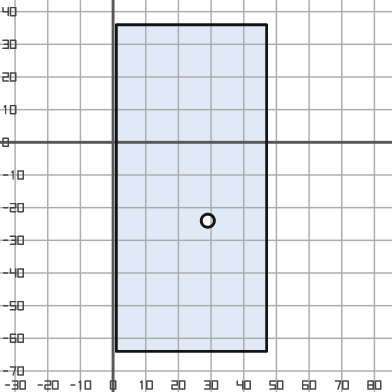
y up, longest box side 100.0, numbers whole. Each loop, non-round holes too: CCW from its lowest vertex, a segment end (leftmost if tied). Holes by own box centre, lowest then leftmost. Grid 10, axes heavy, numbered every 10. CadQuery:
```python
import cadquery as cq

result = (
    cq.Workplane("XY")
    .moveTo(1.0, -64.0)
    .lineTo(47.0, -64.0)
    .lineTo(47.0, 36.0)
    .lineTo(1.0, 36.0)
    .close()
    .moveTo(29.0, -24.0)
    .circle(2.0)
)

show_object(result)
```